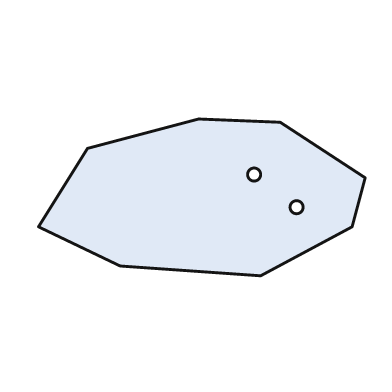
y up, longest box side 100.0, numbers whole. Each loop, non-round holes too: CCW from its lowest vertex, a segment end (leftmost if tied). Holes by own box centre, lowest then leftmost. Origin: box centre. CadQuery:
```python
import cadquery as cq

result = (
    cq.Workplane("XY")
    .moveTo(18.0, -24.0)
    .lineTo(46.0, -9.0)
    .lineTo(50.0, 6.0)
    .lineTo(24.0, 23.0)
    .lineTo(-1.0, 24.0)
    .lineTo(-35.0, 15.0)
    .lineTo(-50.0, -9.0)
    .lineTo(-25.0, -21.0)
    .close()
    .moveTo(29.0, -3.0)
    .circle(2.0)
    .moveTo(16.0, 7.0)
    .circle(2.0)
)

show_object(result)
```